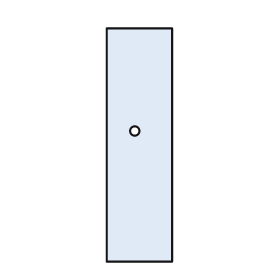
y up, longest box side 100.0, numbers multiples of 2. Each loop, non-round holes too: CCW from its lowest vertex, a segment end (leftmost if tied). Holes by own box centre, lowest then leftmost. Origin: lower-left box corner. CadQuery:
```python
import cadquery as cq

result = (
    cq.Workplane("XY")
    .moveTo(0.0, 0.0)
    .lineTo(28.0, 0.0)
    .lineTo(28.0, 100.0)
    .lineTo(0.0, 100.0)
    .close()
    .moveTo(12.0, 56.0)
    .circle(2.0)
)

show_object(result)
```